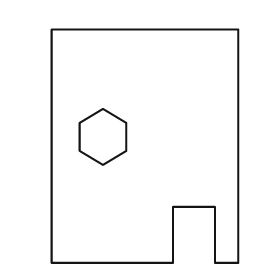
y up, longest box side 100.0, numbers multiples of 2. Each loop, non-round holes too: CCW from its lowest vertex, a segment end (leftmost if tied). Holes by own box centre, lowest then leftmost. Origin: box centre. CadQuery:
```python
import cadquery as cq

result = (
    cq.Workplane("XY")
    .moveTo(-40.0, -50.0)
    .lineTo(12.0, -50.0)
    .lineTo(12.0, -26.0)
    .lineTo(30.0, -26.0)
    .lineTo(30.0, -50.0)
    .lineTo(40.0, -50.0)
    .lineTo(40.0, 50.0)
    .lineTo(-40.0, 50.0)
    .close()
    .moveTo(-18.0, -8.0)
    .lineTo(-8.0, -2.0)
    .lineTo(-8.0, 10.0)
    .lineTo(-18.0, 16.0)
    .lineTo(-28.0, 10.0)
    .lineTo(-28.0, -2.0)
    .close()
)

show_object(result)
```